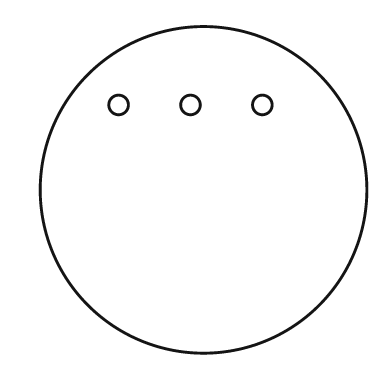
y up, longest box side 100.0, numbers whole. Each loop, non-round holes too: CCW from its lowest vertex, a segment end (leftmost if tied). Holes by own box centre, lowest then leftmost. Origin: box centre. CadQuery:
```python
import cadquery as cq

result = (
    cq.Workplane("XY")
    .moveTo(0.0, 0.0)
    .circle(50.0)
    .moveTo(-26.0, 26.0)
    .circle(3.0)
    .moveTo(-4.0, 26.0)
    .circle(3.0)
    .moveTo(18.0, 26.0)
    .circle(3.0)
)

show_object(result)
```